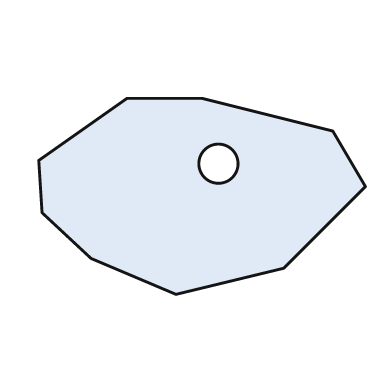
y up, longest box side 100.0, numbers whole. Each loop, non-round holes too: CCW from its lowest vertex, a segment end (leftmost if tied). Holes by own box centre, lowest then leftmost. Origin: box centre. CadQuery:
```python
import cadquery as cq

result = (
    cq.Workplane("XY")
    .moveTo(-8.0, -30.0)
    .lineTo(25.0, -22.0)
    .lineTo(50.0, 3.0)
    .lineTo(40.0, 20.0)
    .lineTo(0.0, 30.0)
    .lineTo(-23.0, 30.0)
    .lineTo(-50.0, 11.0)
    .lineTo(-49.0, -5.0)
    .lineTo(-34.0, -19.0)
    .close()
    .moveTo(5.0, 10.0)
    .circle(6.0)
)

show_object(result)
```